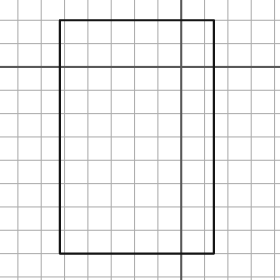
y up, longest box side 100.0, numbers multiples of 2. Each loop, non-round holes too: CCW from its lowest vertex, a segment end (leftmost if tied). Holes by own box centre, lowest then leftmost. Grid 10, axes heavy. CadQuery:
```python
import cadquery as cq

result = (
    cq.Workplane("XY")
    .moveTo(-52.0, -80.0)
    .lineTo(14.0, -80.0)
    .lineTo(14.0, 20.0)
    .lineTo(-52.0, 20.0)
    .close()
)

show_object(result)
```